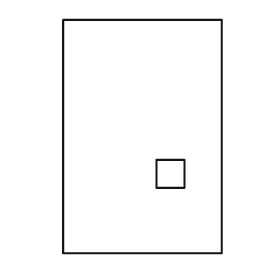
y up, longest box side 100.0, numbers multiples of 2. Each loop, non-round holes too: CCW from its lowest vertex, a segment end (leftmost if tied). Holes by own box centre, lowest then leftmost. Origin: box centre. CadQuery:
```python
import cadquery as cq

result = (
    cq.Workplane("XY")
    .moveTo(-34.0, -50.0)
    .lineTo(34.0, -50.0)
    .lineTo(34.0, 50.0)
    .lineTo(-34.0, 50.0)
    .close()
    .moveTo(6.0, -22.0)
    .lineTo(18.0, -22.0)
    .lineTo(18.0, -10.0)
    .lineTo(6.0, -10.0)
    .close()
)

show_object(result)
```